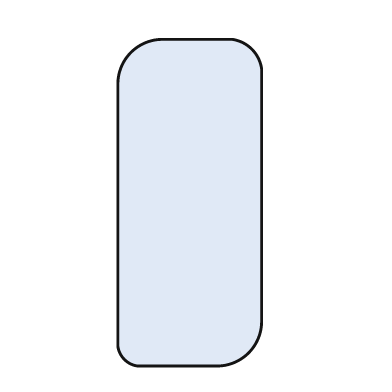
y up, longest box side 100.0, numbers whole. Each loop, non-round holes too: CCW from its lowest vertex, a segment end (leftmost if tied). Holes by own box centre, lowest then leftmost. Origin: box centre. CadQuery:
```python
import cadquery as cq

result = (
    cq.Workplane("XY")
    .moveTo(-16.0, -50.0)
    .lineTo(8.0, -50.0)
    .threePointArc((18.0, -46.0), (22.0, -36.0))
    .lineTo(22.0, 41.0)
    .threePointArc((19.0, 47.0), (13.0, 50.0))
    .lineTo(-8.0, 50.0)
    .threePointArc((-18.0, 46.0), (-22.0, 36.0))
    .lineTo(-22.0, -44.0)
    .threePointArc((-20.0, -48.0), (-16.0, -50.0))
    .close()
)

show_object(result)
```